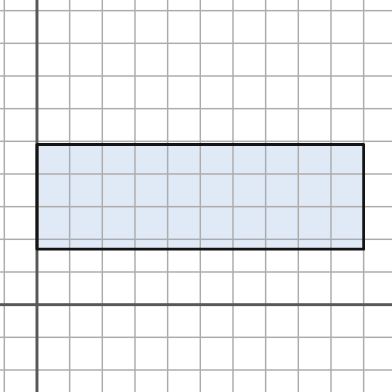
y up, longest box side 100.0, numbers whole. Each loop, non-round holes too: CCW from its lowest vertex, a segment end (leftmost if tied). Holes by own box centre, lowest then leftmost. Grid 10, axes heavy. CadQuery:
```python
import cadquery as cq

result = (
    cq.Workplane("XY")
    .moveTo(0.0, 17.0)
    .lineTo(100.0, 17.0)
    .lineTo(100.0, 49.0)
    .lineTo(0.0, 49.0)
    .close()
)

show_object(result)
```